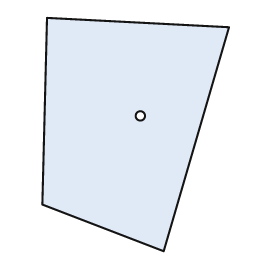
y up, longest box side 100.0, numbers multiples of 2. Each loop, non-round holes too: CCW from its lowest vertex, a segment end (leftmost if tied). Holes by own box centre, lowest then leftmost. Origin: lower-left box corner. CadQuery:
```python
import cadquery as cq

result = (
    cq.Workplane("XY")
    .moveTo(52.0, 0.0)
    .lineTo(80.0, 96.0)
    .lineTo(2.0, 100.0)
    .lineTo(0.0, 20.0)
    .close()
    .moveTo(42.0, 58.0)
    .circle(2.0)
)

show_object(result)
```